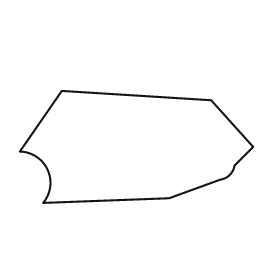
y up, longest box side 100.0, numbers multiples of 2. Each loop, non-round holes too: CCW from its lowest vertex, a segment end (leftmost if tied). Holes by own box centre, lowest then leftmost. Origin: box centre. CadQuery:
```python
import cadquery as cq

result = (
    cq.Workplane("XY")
    .moveTo(-40.0, -24.0)
    .lineTo(14.0, -22.0)
    .lineTo(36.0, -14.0)
    .threePointArc((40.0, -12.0), (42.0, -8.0))
    .lineTo(50.0, 0.0)
    .lineTo(32.0, 20.0)
    .lineTo(-32.0, 24.0)
    .lineTo(-50.0, -2.0)
    .threePointArc((-38.0, -10.0), (-40.0, -24.0))
    .close()
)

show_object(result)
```